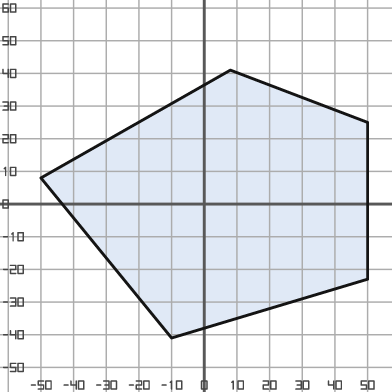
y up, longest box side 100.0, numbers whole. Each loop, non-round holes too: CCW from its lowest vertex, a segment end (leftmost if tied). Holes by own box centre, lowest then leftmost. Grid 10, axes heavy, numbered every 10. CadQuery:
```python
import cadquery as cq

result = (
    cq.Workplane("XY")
    .moveTo(-10.0, -41.0)
    .lineTo(50.0, -23.0)
    .lineTo(50.0, 25.0)
    .lineTo(8.0, 41.0)
    .lineTo(-50.0, 8.0)
    .close()
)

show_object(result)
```